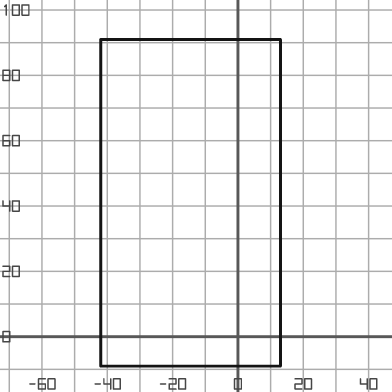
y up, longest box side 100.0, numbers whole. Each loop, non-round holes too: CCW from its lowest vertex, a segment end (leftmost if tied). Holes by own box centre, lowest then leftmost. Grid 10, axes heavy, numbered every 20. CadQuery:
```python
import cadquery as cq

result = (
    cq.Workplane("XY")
    .moveTo(-42.0, -9.0)
    .lineTo(13.0, -9.0)
    .lineTo(13.0, 91.0)
    .lineTo(-42.0, 91.0)
    .close()
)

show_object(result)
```